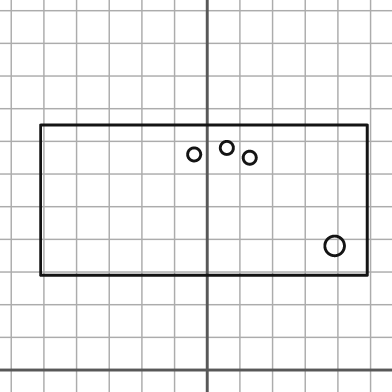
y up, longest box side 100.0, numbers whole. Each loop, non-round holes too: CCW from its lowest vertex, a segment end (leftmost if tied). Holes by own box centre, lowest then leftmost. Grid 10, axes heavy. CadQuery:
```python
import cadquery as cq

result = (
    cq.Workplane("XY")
    .moveTo(-51.0, 29.0)
    .lineTo(49.0, 29.0)
    .lineTo(49.0, 75.0)
    .lineTo(-51.0, 75.0)
    .close()
    .moveTo(39.0, 38.0)
    .circle(3.0)
    .moveTo(13.0, 65.0)
    .circle(2.0)
    .moveTo(-4.0, 66.0)
    .circle(2.0)
    .moveTo(6.0, 68.0)
    .circle(2.0)
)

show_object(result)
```